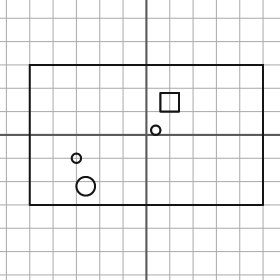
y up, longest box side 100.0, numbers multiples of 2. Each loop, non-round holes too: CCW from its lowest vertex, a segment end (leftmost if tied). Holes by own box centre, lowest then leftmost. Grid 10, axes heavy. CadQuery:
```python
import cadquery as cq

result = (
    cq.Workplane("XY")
    .moveTo(-50.0, -30.0)
    .lineTo(50.0, -30.0)
    .lineTo(50.0, 30.0)
    .lineTo(-50.0, 30.0)
    .close()
    .moveTo(-26.0, -22.0)
    .circle(4.0)
    .moveTo(-30.0, -10.0)
    .circle(2.0)
    .moveTo(4.0, 2.0)
    .circle(2.0)
    .moveTo(6.0, 10.0)
    .lineTo(14.0, 10.0)
    .lineTo(14.0, 18.0)
    .lineTo(6.0, 18.0)
    .close()
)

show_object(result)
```